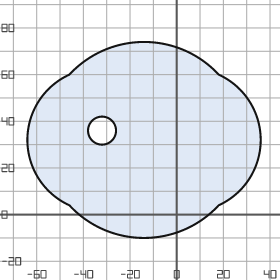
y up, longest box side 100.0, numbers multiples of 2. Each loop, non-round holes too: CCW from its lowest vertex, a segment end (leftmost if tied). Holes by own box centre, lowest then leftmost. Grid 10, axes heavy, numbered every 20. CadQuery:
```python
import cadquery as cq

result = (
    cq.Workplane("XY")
    .moveTo(-46.0, 4.0)
    .threePointArc((-14.0, -10.0), (18.0, 4.0))
    .threePointArc((36.0, 32.0), (18.0, 60.0))
    .threePointArc((-14.0, 74.0), (-46.0, 60.0))
    .threePointArc((-64.0, 32.0), (-46.0, 4.0))
    .close()
    .moveTo(-32.0, 36.0)
    .circle(6.0)
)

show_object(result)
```